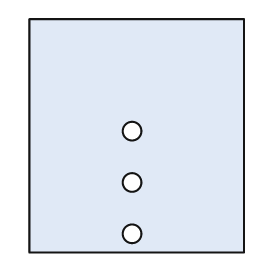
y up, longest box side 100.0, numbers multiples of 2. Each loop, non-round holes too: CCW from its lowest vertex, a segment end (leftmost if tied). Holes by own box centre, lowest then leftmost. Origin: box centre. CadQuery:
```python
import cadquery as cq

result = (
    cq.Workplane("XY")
    .moveTo(-46.0, -50.0)
    .lineTo(46.0, -50.0)
    .lineTo(46.0, 50.0)
    .lineTo(-46.0, 50.0)
    .close()
    .moveTo(-2.0, -42.0)
    .circle(4.0)
    .moveTo(-2.0, -20.0)
    .circle(4.0)
    .moveTo(-2.0, 2.0)
    .circle(4.0)
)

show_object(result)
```